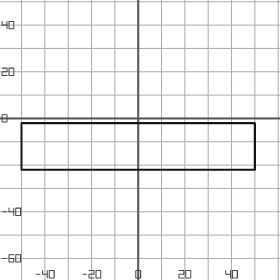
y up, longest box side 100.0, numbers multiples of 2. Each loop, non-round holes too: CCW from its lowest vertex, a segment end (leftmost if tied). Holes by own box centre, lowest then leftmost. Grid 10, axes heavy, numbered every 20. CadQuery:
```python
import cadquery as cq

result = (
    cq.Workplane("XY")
    .moveTo(-50.0, -22.0)
    .lineTo(50.0, -22.0)
    .lineTo(50.0, -2.0)
    .lineTo(-50.0, -2.0)
    .close()
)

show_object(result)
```